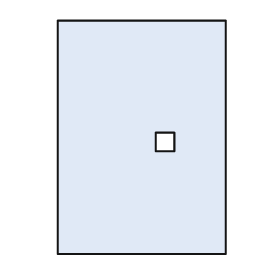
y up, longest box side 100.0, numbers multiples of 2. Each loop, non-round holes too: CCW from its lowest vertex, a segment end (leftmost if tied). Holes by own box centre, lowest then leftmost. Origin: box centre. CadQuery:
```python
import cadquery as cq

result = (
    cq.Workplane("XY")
    .moveTo(-36.0, -50.0)
    .lineTo(36.0, -50.0)
    .lineTo(36.0, 50.0)
    .lineTo(-36.0, 50.0)
    .close()
    .moveTo(6.0, -6.0)
    .lineTo(14.0, -6.0)
    .lineTo(14.0, 2.0)
    .lineTo(6.0, 2.0)
    .close()
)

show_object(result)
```